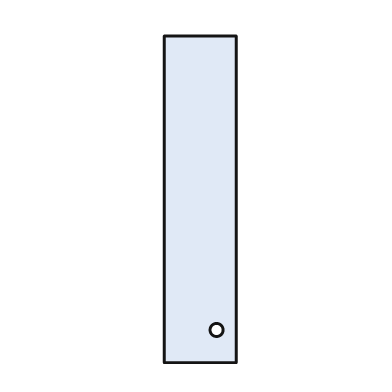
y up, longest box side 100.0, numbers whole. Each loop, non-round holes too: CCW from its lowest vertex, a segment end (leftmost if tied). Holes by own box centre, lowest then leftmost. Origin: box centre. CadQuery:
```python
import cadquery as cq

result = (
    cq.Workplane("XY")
    .moveTo(-11.0, -50.0)
    .lineTo(11.0, -50.0)
    .lineTo(11.0, 50.0)
    .lineTo(-11.0, 50.0)
    .close()
    .moveTo(5.0, -40.0)
    .circle(2.0)
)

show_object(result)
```